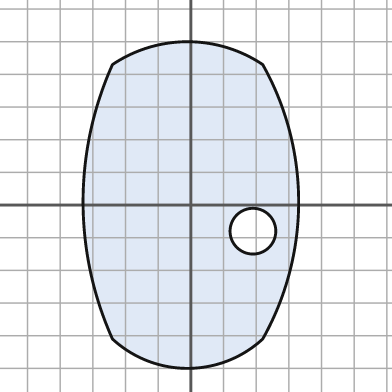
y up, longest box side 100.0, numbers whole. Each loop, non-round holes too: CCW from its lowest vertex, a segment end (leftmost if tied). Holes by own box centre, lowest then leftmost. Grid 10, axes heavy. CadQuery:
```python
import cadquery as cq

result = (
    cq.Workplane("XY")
    .moveTo(-24.0, -41.0)
    .threePointArc((-1.0, -50.0), (22.0, -41.0))
    .threePointArc((33.0, 1.0), (22.0, 43.0))
    .threePointArc((-1.0, 50.0), (-24.0, 43.0))
    .threePointArc((-33.0, 1.0), (-24.0, -41.0))
    .close()
    .moveTo(19.0, -8.0)
    .circle(7.0)
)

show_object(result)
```